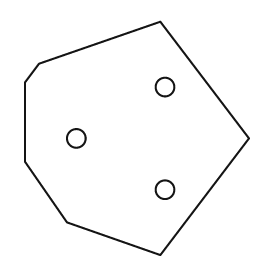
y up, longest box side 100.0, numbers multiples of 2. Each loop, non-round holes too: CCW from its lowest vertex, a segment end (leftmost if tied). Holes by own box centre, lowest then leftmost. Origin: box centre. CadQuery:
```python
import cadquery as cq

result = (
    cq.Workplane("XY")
    .moveTo(10.0, -50.0)
    .lineTo(48.0, 0.0)
    .lineTo(10.0, 50.0)
    .lineTo(-42.0, 32.0)
    .lineTo(-48.0, 24.0)
    .lineTo(-48.0, -10.0)
    .lineTo(-30.0, -36.0)
    .close()
    .moveTo(12.0, -22.0)
    .circle(4.0)
    .moveTo(-26.0, 0.0)
    .circle(4.0)
    .moveTo(12.0, 22.0)
    .circle(4.0)
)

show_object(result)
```